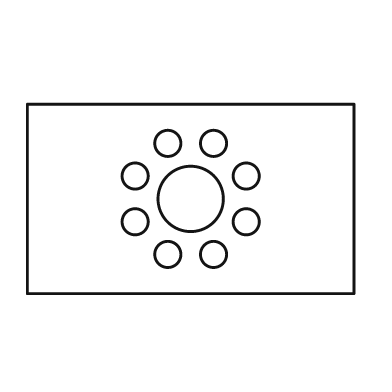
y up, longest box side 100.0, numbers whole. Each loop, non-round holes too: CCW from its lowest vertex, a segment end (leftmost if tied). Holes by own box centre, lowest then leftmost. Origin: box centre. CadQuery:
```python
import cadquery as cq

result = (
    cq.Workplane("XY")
    .moveTo(-50.0, -29.0)
    .lineTo(50.0, -29.0)
    .lineTo(50.0, 29.0)
    .lineTo(-50.0, 29.0)
    .close()
    .moveTo(-7.0, -17.0)
    .circle(4.0)
    .moveTo(7.0, -17.0)
    .circle(4.0)
    .moveTo(-17.0, -7.0)
    .circle(4.0)
    .moveTo(17.0, -7.0)
    .circle(4.0)
    .moveTo(0.0, 0.0)
    .circle(10.0)
    .moveTo(-17.0, 7.0)
    .circle(4.0)
    .moveTo(17.0, 7.0)
    .circle(4.0)
    .moveTo(-7.0, 17.0)
    .circle(4.0)
    .moveTo(7.0, 17.0)
    .circle(4.0)
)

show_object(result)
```